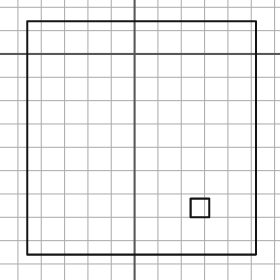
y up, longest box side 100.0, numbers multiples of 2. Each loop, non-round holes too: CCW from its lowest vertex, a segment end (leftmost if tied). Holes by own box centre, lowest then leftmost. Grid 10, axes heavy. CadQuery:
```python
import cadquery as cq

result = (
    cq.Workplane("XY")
    .moveTo(-46.0, -86.0)
    .lineTo(52.0, -86.0)
    .lineTo(52.0, 14.0)
    .lineTo(-46.0, 14.0)
    .close()
    .moveTo(24.0, -70.0)
    .lineTo(32.0, -70.0)
    .lineTo(32.0, -62.0)
    .lineTo(24.0, -62.0)
    .close()
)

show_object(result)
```